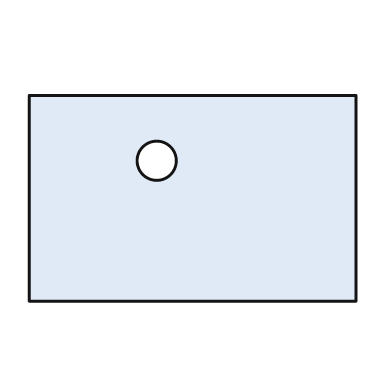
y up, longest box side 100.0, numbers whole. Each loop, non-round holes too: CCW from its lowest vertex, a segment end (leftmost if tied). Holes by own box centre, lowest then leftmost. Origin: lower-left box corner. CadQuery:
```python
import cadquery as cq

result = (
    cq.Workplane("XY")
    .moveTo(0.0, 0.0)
    .lineTo(100.0, 0.0)
    .lineTo(100.0, 63.0)
    .lineTo(0.0, 63.0)
    .close()
    .moveTo(39.0, 43.0)
    .circle(6.0)
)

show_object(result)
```